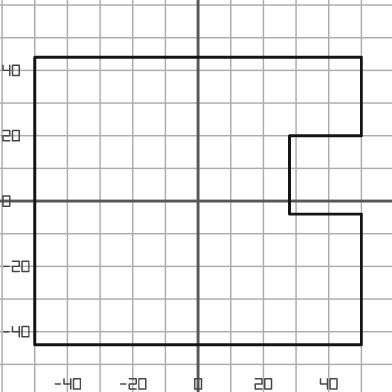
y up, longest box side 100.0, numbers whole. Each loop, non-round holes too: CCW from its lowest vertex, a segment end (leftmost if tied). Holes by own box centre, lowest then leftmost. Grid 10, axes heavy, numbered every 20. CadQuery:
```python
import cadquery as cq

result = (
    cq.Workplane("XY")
    .moveTo(-50.0, -44.0)
    .lineTo(50.0, -44.0)
    .lineTo(50.0, -4.0)
    .lineTo(28.0, -4.0)
    .lineTo(28.0, 20.0)
    .lineTo(50.0, 20.0)
    .lineTo(50.0, 44.0)
    .lineTo(-50.0, 44.0)
    .close()
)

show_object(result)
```